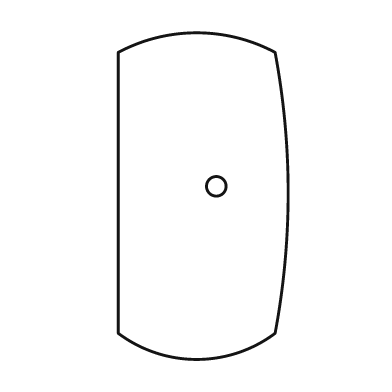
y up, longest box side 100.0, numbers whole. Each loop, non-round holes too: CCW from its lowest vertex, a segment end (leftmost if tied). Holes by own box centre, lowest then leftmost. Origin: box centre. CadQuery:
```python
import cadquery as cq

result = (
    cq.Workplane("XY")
    .moveTo(-26.0, -42.0)
    .threePointArc((-2.0, -50.0), (22.0, -42.0))
    .threePointArc((26.0, 1.0), (22.0, 44.0))
    .threePointArc((-2.0, 50.0), (-26.0, 44.0))
    .close()
    .moveTo(4.0, 3.0)
    .circle(3.0)
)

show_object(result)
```